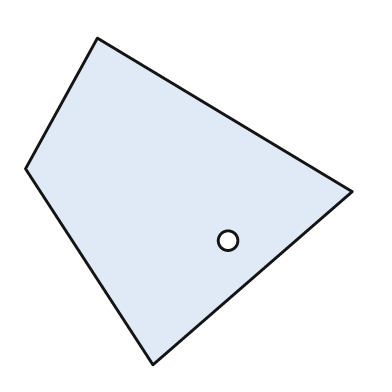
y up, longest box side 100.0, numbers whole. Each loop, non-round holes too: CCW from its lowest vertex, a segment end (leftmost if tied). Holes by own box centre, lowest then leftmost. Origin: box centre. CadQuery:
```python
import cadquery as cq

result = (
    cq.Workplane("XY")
    .moveTo(-11.0, -50.0)
    .lineTo(50.0, 3.0)
    .lineTo(-28.0, 50.0)
    .lineTo(-50.0, 10.0)
    .close()
    .moveTo(12.0, -12.0)
    .circle(3.0)
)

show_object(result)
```